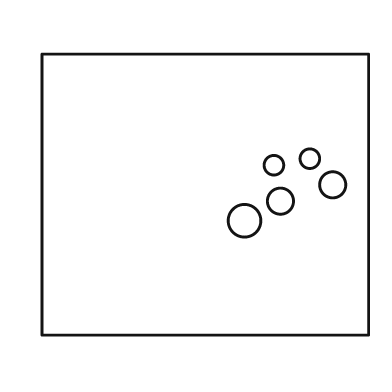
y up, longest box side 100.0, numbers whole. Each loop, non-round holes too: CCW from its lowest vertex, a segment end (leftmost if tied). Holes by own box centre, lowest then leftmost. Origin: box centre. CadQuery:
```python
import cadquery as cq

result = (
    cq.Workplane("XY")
    .moveTo(-50.0, -43.0)
    .lineTo(50.0, -43.0)
    .lineTo(50.0, 43.0)
    .lineTo(-50.0, 43.0)
    .close()
    .moveTo(12.0, -8.0)
    .circle(5.0)
    .moveTo(23.0, -2.0)
    .circle(4.0)
    .moveTo(39.0, 3.0)
    .circle(4.0)
    .moveTo(21.0, 9.0)
    .circle(3.0)
    .moveTo(32.0, 11.0)
    .circle(3.0)
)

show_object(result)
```